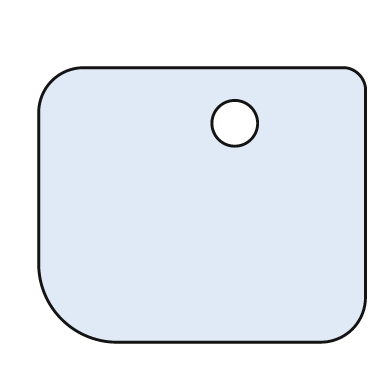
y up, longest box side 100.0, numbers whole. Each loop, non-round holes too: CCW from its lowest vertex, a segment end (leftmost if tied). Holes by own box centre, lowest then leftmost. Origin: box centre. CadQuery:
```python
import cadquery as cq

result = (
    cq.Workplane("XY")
    .moveTo(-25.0, -42.0)
    .lineTo(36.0, -42.0)
    .threePointArc((46.0, -38.0), (50.0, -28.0))
    .lineTo(50.0, 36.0)
    .threePointArc((48.0, 40.0), (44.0, 42.0))
    .lineTo(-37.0, 42.0)
    .threePointArc((-46.0, 38.0), (-50.0, 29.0))
    .lineTo(-50.0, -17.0)
    .threePointArc((-43.0, -35.0), (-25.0, -42.0))
    .close()
    .moveTo(10.0, 25.0)
    .circle(7.0)
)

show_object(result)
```